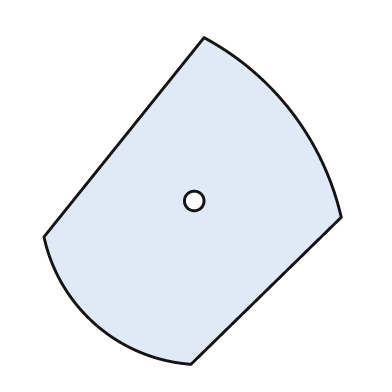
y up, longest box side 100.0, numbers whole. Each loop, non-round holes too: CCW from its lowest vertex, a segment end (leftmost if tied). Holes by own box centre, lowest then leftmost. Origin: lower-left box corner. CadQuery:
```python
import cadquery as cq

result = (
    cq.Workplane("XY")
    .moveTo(45.0, 0.0)
    .lineTo(91.0, 45.0)
    .threePointArc((76.0, 77.0), (49.0, 100.0))
    .lineTo(0.0, 39.0)
    .threePointArc((16.0, 12.0), (45.0, 0.0))
    .close()
    .moveTo(46.0, 50.0)
    .circle(3.0)
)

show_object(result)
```